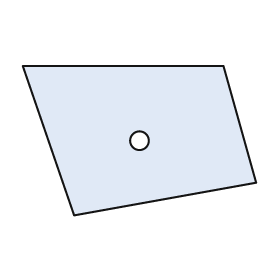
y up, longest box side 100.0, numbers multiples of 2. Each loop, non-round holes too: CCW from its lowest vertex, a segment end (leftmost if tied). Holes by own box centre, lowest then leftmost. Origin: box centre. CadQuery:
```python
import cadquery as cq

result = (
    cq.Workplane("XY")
    .moveTo(-28.0, -32.0)
    .lineTo(50.0, -18.0)
    .lineTo(36.0, 32.0)
    .lineTo(-50.0, 32.0)
    .close()
    .moveTo(0.0, 0.0)
    .circle(4.0)
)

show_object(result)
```